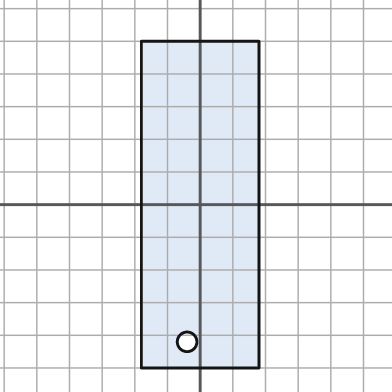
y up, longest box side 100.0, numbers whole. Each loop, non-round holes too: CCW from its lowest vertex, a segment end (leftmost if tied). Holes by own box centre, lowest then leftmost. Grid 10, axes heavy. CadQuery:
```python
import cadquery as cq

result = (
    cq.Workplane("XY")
    .moveTo(-18.0, -50.0)
    .lineTo(18.0, -50.0)
    .lineTo(18.0, 50.0)
    .lineTo(-18.0, 50.0)
    .close()
    .moveTo(-4.0, -42.0)
    .circle(3.0)
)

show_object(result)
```